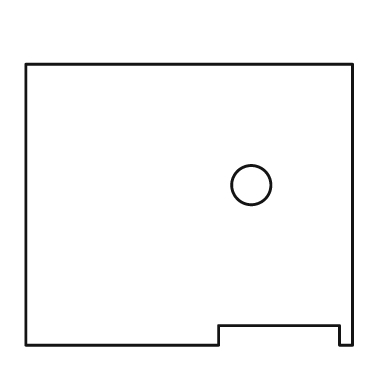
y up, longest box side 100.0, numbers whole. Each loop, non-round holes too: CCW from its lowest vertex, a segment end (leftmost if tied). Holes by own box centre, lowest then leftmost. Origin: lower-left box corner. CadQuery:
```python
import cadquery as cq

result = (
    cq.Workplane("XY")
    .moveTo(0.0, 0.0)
    .lineTo(59.0, 0.0)
    .lineTo(59.0, 6.0)
    .lineTo(96.0, 6.0)
    .lineTo(96.0, 0.0)
    .lineTo(100.0, 0.0)
    .lineTo(100.0, 86.0)
    .lineTo(0.0, 86.0)
    .close()
    .moveTo(69.0, 49.0)
    .circle(6.0)
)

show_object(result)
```